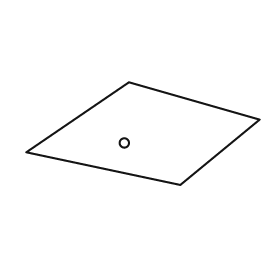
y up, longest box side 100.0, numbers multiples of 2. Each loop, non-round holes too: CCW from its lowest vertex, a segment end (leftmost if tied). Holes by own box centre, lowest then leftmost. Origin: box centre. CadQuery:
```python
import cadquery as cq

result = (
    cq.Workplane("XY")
    .moveTo(16.0, -22.0)
    .lineTo(50.0, 6.0)
    .lineTo(-6.0, 22.0)
    .lineTo(-50.0, -8.0)
    .close()
    .moveTo(-8.0, -4.0)
    .circle(2.0)
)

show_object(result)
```